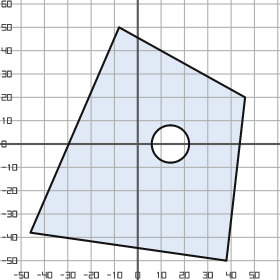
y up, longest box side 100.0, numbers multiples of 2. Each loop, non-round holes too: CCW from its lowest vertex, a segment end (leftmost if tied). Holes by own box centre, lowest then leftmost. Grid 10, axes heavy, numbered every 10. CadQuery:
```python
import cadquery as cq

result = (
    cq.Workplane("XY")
    .moveTo(38.0, -50.0)
    .lineTo(46.0, 20.0)
    .lineTo(-8.0, 50.0)
    .lineTo(-46.0, -38.0)
    .close()
    .moveTo(14.0, 0.0)
    .circle(8.0)
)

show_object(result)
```